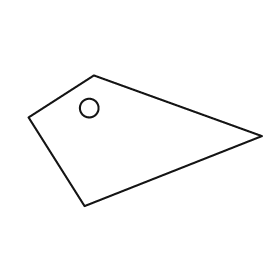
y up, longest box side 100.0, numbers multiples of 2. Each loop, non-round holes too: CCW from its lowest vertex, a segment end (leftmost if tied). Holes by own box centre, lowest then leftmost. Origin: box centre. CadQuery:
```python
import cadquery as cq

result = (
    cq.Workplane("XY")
    .moveTo(-26.0, -28.0)
    .lineTo(50.0, 2.0)
    .lineTo(-22.0, 28.0)
    .lineTo(-50.0, 10.0)
    .close()
    .moveTo(-24.0, 14.0)
    .circle(4.0)
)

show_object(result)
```